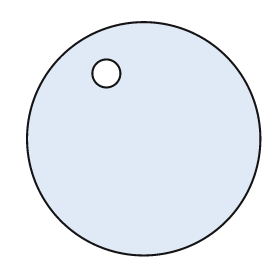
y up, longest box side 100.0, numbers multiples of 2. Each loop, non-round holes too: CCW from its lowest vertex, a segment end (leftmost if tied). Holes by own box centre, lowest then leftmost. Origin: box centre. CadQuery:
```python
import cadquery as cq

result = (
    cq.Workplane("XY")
    .moveTo(0.0, 0.0)
    .circle(50.0)
    .moveTo(-16.0, 28.0)
    .circle(6.0)
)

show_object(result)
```